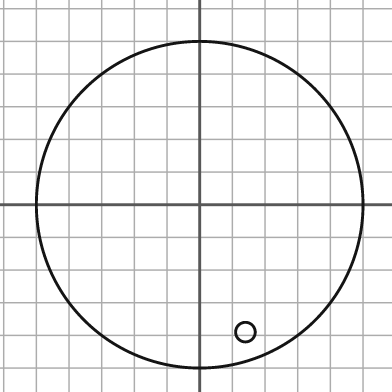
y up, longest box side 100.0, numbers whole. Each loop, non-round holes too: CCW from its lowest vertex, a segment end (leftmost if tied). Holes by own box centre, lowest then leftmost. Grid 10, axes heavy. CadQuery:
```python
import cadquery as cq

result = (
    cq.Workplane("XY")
    .moveTo(0.0, 0.0)
    .circle(50.0)
    .moveTo(14.0, -39.0)
    .circle(3.0)
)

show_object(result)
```